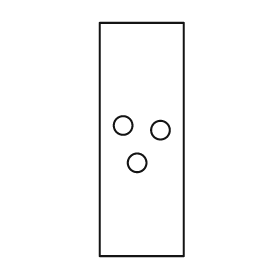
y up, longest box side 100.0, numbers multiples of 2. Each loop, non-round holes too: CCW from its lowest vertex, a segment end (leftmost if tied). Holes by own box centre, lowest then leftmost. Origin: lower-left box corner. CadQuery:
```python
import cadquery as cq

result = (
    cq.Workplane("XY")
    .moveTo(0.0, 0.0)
    .lineTo(36.0, 0.0)
    .lineTo(36.0, 100.0)
    .lineTo(0.0, 100.0)
    .close()
    .moveTo(16.0, 40.0)
    .circle(4.0)
    .moveTo(26.0, 54.0)
    .circle(4.0)
    .moveTo(10.0, 56.0)
    .circle(4.0)
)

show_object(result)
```